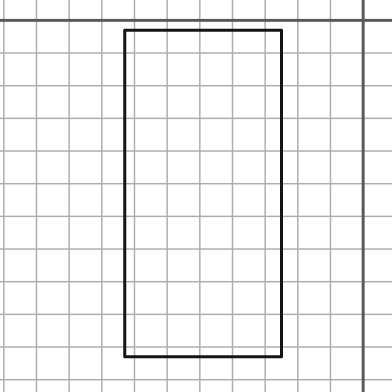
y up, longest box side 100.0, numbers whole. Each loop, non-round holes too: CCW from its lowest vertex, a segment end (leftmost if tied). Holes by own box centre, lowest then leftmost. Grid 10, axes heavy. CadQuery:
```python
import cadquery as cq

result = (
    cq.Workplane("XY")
    .moveTo(-73.0, -103.0)
    .lineTo(-25.0, -103.0)
    .lineTo(-25.0, -3.0)
    .lineTo(-73.0, -3.0)
    .close()
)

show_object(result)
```